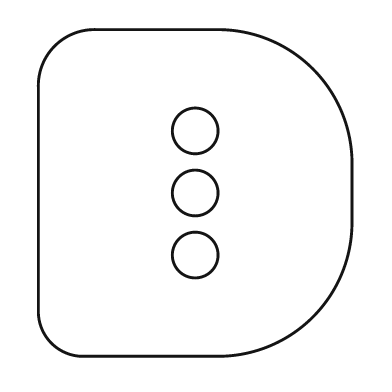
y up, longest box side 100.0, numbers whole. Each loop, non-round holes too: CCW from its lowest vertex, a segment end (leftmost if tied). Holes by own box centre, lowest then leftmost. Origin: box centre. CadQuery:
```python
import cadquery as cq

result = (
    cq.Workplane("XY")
    .moveTo(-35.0, -50.0)
    .lineTo(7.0, -50.0)
    .threePointArc((36.0, -38.0), (48.0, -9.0))
    .lineTo(48.0, 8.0)
    .threePointArc((36.0, 38.0), (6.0, 50.0))
    .lineTo(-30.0, 50.0)
    .threePointArc((-43.0, 45.0), (-48.0, 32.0))
    .lineTo(-48.0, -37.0)
    .threePointArc((-44.0, -46.0), (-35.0, -50.0))
    .close()
    .moveTo(0.0, -19.0)
    .circle(7.0)
    .moveTo(0.0, 0.0)
    .circle(7.0)
    .moveTo(0.0, 19.0)
    .circle(7.0)
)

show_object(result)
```